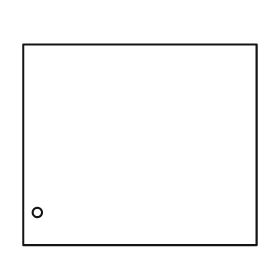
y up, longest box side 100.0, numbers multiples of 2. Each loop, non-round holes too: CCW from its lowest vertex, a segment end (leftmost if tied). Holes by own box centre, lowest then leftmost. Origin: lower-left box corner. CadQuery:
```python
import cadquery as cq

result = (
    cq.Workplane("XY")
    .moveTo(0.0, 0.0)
    .lineTo(100.0, 0.0)
    .lineTo(100.0, 86.0)
    .lineTo(0.0, 86.0)
    .close()
    .moveTo(6.0, 14.0)
    .circle(2.0)
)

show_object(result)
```